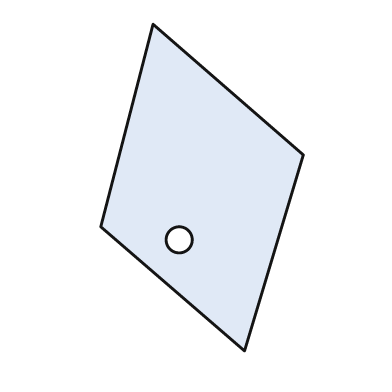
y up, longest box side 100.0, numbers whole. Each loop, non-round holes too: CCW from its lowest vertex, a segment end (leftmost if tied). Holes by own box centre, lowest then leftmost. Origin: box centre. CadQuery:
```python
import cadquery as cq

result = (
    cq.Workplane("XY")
    .moveTo(13.0, -50.0)
    .lineTo(31.0, 10.0)
    .lineTo(-15.0, 50.0)
    .lineTo(-31.0, -12.0)
    .close()
    .moveTo(-7.0, -16.0)
    .circle(4.0)
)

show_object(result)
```